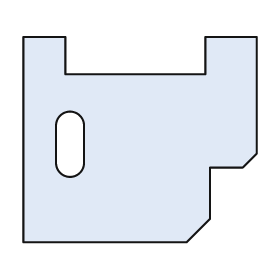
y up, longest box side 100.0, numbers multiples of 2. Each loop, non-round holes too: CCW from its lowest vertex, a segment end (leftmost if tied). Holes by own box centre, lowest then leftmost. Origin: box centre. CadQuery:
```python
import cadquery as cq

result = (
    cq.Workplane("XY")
    .moveTo(-50.0, -44.0)
    .lineTo(20.0, -44.0)
    .lineTo(30.0, -34.0)
    .lineTo(30.0, -12.0)
    .lineTo(44.0, -12.0)
    .lineTo(50.0, -6.0)
    .lineTo(50.0, 44.0)
    .lineTo(28.0, 44.0)
    .lineTo(28.0, 28.0)
    .lineTo(-32.0, 28.0)
    .lineTo(-32.0, 44.0)
    .lineTo(-50.0, 44.0)
    .close()
    .moveTo(-36.0, -10.0)
    .threePointArc((-30.0, -16.0), (-24.0, -10.0))
    .lineTo(-24.0, 6.0)
    .threePointArc((-30.0, 12.0), (-36.0, 6.0))
    .close()
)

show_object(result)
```